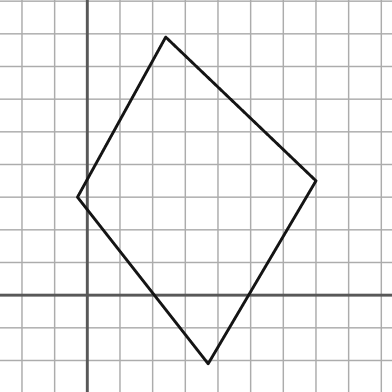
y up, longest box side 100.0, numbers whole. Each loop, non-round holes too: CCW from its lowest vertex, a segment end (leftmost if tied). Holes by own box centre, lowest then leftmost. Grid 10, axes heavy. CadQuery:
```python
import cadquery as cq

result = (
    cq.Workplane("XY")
    .moveTo(37.0, -21.0)
    .lineTo(70.0, 35.0)
    .lineTo(24.0, 79.0)
    .lineTo(-3.0, 30.0)
    .close()
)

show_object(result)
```